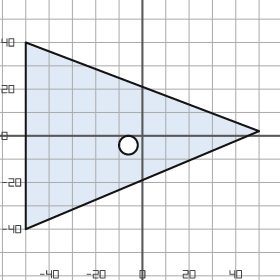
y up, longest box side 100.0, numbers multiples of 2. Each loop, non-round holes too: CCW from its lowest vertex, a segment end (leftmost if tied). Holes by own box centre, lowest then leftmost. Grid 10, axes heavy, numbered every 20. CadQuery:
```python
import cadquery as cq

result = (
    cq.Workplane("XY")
    .moveTo(-50.0, -40.0)
    .lineTo(50.0, 2.0)
    .lineTo(-50.0, 40.0)
    .close()
    .moveTo(-6.0, -4.0)
    .circle(4.0)
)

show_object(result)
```